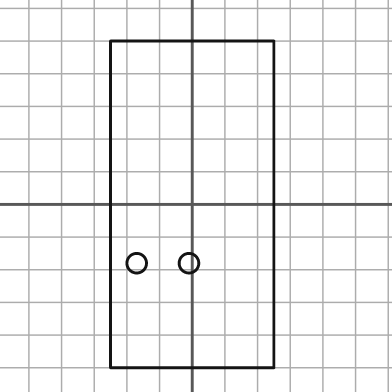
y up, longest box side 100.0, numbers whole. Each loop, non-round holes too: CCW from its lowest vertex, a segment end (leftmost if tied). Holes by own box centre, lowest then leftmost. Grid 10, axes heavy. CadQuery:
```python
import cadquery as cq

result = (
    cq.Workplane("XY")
    .moveTo(-25.0, -50.0)
    .lineTo(25.0, -50.0)
    .lineTo(25.0, 50.0)
    .lineTo(-25.0, 50.0)
    .close()
    .moveTo(-17.0, -18.0)
    .circle(3.0)
    .moveTo(-1.0, -18.0)
    .circle(3.0)
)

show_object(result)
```